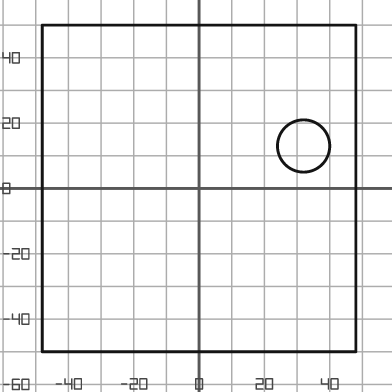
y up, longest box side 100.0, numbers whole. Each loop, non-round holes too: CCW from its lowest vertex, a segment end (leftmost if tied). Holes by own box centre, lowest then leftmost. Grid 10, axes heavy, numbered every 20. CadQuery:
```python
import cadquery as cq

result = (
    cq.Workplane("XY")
    .moveTo(-48.0, -50.0)
    .lineTo(48.0, -50.0)
    .lineTo(48.0, 50.0)
    .lineTo(-48.0, 50.0)
    .close()
    .moveTo(32.0, 13.0)
    .circle(8.0)
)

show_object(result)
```